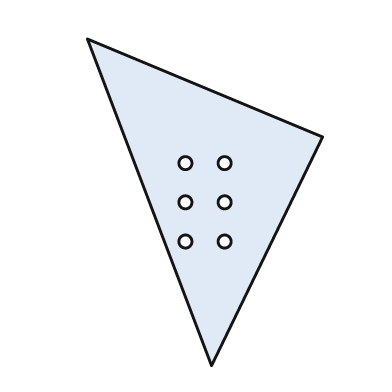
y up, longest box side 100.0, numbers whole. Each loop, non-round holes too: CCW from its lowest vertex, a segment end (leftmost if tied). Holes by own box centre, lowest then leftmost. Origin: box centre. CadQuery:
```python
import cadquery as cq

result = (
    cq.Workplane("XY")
    .moveTo(2.0, -50.0)
    .lineTo(36.0, 20.0)
    .lineTo(-36.0, 50.0)
    .close()
    .moveTo(-6.0, -12.0)
    .circle(2.0)
    .moveTo(6.0, -12.0)
    .circle(2.0)
    .moveTo(-6.0, 0.0)
    .circle(2.0)
    .moveTo(6.0, 0.0)
    .circle(2.0)
    .moveTo(-6.0, 12.0)
    .circle(2.0)
    .moveTo(6.0, 12.0)
    .circle(2.0)
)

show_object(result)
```